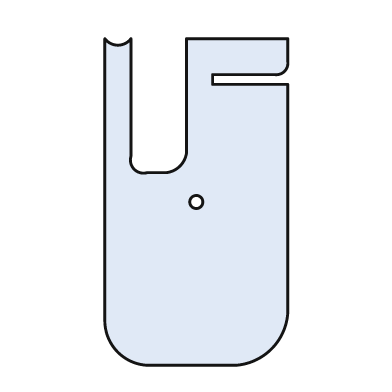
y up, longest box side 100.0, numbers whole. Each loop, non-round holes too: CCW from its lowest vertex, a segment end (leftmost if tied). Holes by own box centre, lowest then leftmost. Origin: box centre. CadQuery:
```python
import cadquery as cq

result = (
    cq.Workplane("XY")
    .moveTo(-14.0, -50.0)
    .lineTo(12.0, -50.0)
    .threePointArc((23.0, -45.0), (28.0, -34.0))
    .lineTo(28.0, 36.0)
    .lineTo(5.0, 36.0)
    .lineTo(5.0, 39.0)
    .lineTo(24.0, 39.0)
    .threePointArc((27.0, 40.0), (28.0, 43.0))
    .lineTo(28.0, 50.0)
    .lineTo(-3.0, 50.0)
    .lineTo(-3.0, 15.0)
    .threePointArc((-5.0, 11.0), (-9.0, 9.0))
    .lineTo(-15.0, 9.0)
    .threePointArc((-19.0, 10.0), (-20.0, 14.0))
    .lineTo(-20.0, 50.0)
    .threePointArc((-24.0, 48.0), (-28.0, 50.0))
    .lineTo(-28.0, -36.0)
    .threePointArc((-24.0, -46.0), (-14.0, -50.0))
    .close()
    .moveTo(0.0, 0.0)
    .circle(2.0)
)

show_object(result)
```